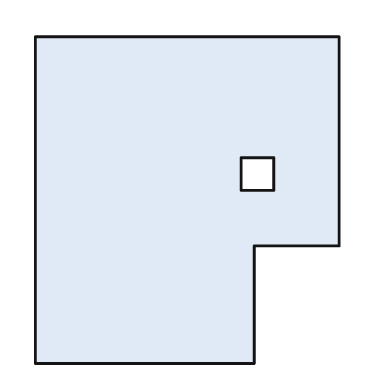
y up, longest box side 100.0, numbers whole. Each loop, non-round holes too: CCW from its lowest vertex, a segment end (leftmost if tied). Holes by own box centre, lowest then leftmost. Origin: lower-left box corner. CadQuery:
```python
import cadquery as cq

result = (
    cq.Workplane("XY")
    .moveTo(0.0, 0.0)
    .lineTo(67.0, 0.0)
    .lineTo(67.0, 36.0)
    .lineTo(93.0, 36.0)
    .lineTo(93.0, 100.0)
    .lineTo(0.0, 100.0)
    .close()
    .moveTo(63.0, 53.0)
    .lineTo(73.0, 53.0)
    .lineTo(73.0, 63.0)
    .lineTo(63.0, 63.0)
    .close()
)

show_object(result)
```